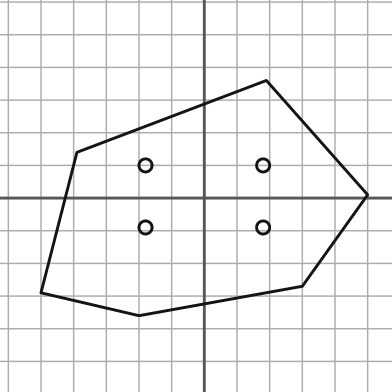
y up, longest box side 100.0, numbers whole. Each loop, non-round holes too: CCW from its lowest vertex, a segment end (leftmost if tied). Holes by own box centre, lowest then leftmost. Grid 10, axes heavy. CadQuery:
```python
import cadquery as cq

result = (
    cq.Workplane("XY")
    .moveTo(-20.0, -36.0)
    .lineTo(30.0, -27.0)
    .lineTo(50.0, 1.0)
    .lineTo(19.0, 36.0)
    .lineTo(-39.0, 14.0)
    .lineTo(-50.0, -29.0)
    .close()
    .moveTo(-18.0, -9.0)
    .circle(2.0)
    .moveTo(18.0, -9.0)
    .circle(2.0)
    .moveTo(-18.0, 10.0)
    .circle(2.0)
    .moveTo(18.0, 10.0)
    .circle(2.0)
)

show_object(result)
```